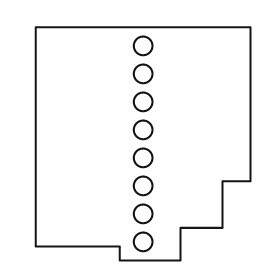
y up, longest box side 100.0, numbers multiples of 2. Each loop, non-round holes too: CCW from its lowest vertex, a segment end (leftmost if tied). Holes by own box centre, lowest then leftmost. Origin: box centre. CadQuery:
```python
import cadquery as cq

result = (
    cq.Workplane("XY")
    .moveTo(-10.0, -50.0)
    .lineTo(16.0, -50.0)
    .lineTo(16.0, -36.0)
    .lineTo(34.0, -36.0)
    .lineTo(34.0, -16.0)
    .lineTo(46.0, -16.0)
    .lineTo(46.0, 50.0)
    .lineTo(-46.0, 50.0)
    .lineTo(-46.0, -44.0)
    .lineTo(-10.0, -44.0)
    .close()
    .moveTo(0.0, -42.0)
    .circle(4.0)
    .moveTo(0.0, -30.0)
    .circle(4.0)
    .moveTo(0.0, -18.0)
    .circle(4.0)
    .moveTo(0.0, -6.0)
    .circle(4.0)
    .moveTo(0.0, 6.0)
    .circle(4.0)
    .moveTo(0.0, 18.0)
    .circle(4.0)
    .moveTo(0.0, 30.0)
    .circle(4.0)
    .moveTo(0.0, 42.0)
    .circle(4.0)
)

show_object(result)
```